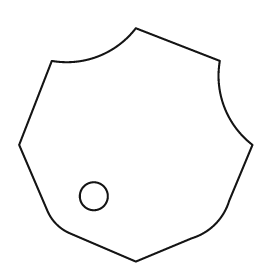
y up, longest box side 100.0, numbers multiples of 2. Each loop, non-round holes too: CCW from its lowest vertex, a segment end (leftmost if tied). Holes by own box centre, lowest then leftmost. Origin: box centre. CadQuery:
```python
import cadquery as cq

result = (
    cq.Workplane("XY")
    .moveTo(0.0, -50.0)
    .lineTo(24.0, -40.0)
    .threePointArc((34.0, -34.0), (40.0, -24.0))
    .lineTo(50.0, 0.0)
    .threePointArc((38.0, 16.0), (36.0, 36.0))
    .lineTo(0.0, 50.0)
    .threePointArc((-16.0, 38.0), (-36.0, 36.0))
    .lineTo(-50.0, 0.0)
    .lineTo(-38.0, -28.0)
    .threePointArc((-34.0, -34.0), (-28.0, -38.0))
    .close()
    .moveTo(-18.0, -22.0)
    .circle(6.0)
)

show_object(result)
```